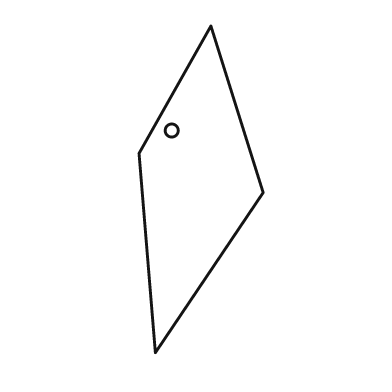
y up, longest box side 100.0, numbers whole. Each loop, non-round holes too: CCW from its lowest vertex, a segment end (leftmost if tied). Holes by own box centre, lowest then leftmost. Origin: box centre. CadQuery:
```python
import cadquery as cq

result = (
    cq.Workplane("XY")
    .moveTo(-14.0, -50.0)
    .lineTo(19.0, -1.0)
    .lineTo(3.0, 50.0)
    .lineTo(-19.0, 11.0)
    .close()
    .moveTo(-9.0, 18.0)
    .circle(2.0)
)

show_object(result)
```